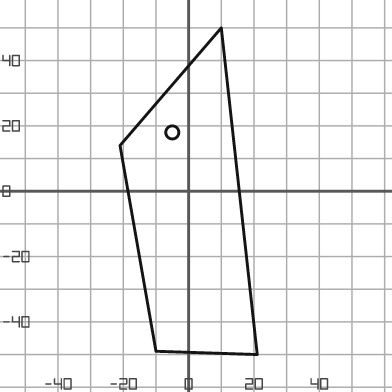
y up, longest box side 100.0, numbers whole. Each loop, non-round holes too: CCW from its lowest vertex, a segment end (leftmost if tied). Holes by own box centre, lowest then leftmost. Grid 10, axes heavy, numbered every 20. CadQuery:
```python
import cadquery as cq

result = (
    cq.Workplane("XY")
    .moveTo(21.0, -50.0)
    .lineTo(10.0, 50.0)
    .lineTo(-21.0, 14.0)
    .lineTo(-10.0, -49.0)
    .close()
    .moveTo(-5.0, 18.0)
    .circle(2.0)
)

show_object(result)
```